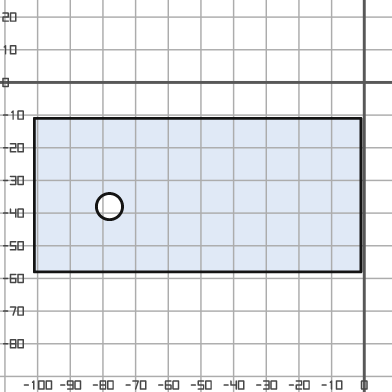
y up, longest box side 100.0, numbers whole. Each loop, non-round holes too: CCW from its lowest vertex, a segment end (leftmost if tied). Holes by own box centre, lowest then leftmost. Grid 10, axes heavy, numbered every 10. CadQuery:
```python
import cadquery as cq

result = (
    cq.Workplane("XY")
    .moveTo(-101.0, -58.0)
    .lineTo(-1.0, -58.0)
    .lineTo(-1.0, -11.0)
    .lineTo(-101.0, -11.0)
    .close()
    .moveTo(-78.0, -38.0)
    .circle(4.0)
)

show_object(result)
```